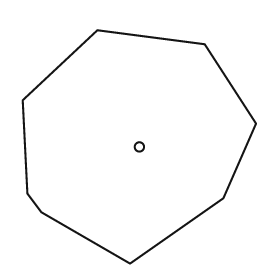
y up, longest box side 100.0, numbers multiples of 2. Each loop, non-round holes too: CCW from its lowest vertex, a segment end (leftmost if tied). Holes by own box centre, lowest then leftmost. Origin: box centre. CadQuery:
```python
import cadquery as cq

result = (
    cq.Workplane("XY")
    .moveTo(-4.0, -50.0)
    .lineTo(36.0, -22.0)
    .lineTo(50.0, 10.0)
    .lineTo(28.0, 44.0)
    .lineTo(-18.0, 50.0)
    .lineTo(-50.0, 20.0)
    .lineTo(-48.0, -20.0)
    .lineTo(-42.0, -28.0)
    .close()
    .moveTo(0.0, 0.0)
    .circle(2.0)
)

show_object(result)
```